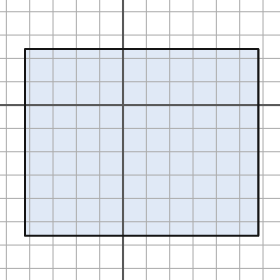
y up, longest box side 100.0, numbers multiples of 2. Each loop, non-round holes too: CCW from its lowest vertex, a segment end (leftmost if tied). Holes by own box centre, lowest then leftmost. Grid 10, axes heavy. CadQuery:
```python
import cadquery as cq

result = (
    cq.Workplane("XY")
    .moveTo(-42.0, -56.0)
    .lineTo(58.0, -56.0)
    .lineTo(58.0, 24.0)
    .lineTo(-42.0, 24.0)
    .close()
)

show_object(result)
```